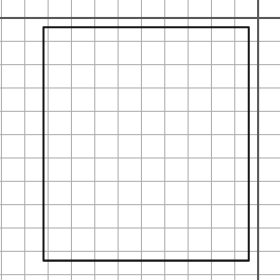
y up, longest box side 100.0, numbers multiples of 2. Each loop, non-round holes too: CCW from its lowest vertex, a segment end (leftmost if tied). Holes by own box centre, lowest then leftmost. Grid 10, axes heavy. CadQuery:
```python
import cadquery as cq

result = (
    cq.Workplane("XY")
    .moveTo(-92.0, -104.0)
    .lineTo(-4.0, -104.0)
    .lineTo(-4.0, -4.0)
    .lineTo(-92.0, -4.0)
    .close()
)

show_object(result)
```